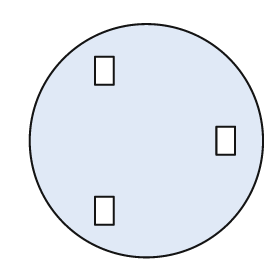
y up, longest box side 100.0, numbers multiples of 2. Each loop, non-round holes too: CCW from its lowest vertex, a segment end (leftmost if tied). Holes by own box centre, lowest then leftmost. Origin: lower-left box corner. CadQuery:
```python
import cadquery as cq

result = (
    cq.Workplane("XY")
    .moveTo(50.0, 50.0)
    .circle(50.0)
    .moveTo(28.0, 14.0)
    .lineTo(36.0, 14.0)
    .lineTo(36.0, 26.0)
    .lineTo(28.0, 26.0)
    .close()
    .moveTo(80.0, 44.0)
    .lineTo(88.0, 44.0)
    .lineTo(88.0, 56.0)
    .lineTo(80.0, 56.0)
    .close()
    .moveTo(28.0, 74.0)
    .lineTo(36.0, 74.0)
    .lineTo(36.0, 86.0)
    .lineTo(28.0, 86.0)
    .close()
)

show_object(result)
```